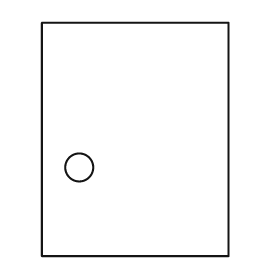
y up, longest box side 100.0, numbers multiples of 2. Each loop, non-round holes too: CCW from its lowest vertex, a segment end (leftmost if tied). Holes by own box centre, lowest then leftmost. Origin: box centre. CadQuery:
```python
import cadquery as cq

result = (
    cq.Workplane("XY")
    .moveTo(-40.0, -50.0)
    .lineTo(40.0, -50.0)
    .lineTo(40.0, 50.0)
    .lineTo(-40.0, 50.0)
    .close()
    .moveTo(-24.0, -12.0)
    .circle(6.0)
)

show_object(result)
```